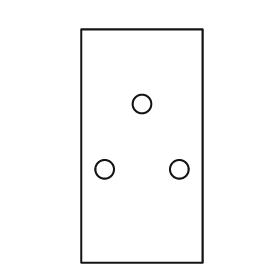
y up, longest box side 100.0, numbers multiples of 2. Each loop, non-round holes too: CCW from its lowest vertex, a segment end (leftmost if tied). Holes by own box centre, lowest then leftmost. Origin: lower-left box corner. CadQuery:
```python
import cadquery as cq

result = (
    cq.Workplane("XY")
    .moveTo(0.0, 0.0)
    .lineTo(52.0, 0.0)
    .lineTo(52.0, 100.0)
    .lineTo(0.0, 100.0)
    .close()
    .moveTo(10.0, 40.0)
    .circle(4.0)
    .moveTo(42.0, 40.0)
    .circle(4.0)
    .moveTo(26.0, 68.0)
    .circle(4.0)
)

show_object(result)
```